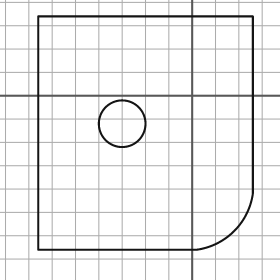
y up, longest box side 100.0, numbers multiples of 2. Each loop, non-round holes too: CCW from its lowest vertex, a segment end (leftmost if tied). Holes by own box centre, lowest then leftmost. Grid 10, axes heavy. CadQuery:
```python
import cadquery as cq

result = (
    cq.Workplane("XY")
    .moveTo(-66.0, -66.0)
    .lineTo(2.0, -66.0)
    .threePointArc((18.0, -58.0), (26.0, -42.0))
    .lineTo(26.0, 34.0)
    .lineTo(-66.0, 34.0)
    .close()
    .moveTo(-30.0, -12.0)
    .circle(10.0)
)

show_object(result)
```